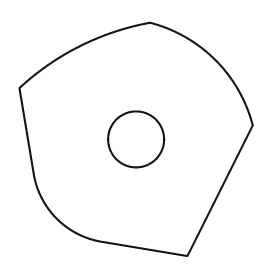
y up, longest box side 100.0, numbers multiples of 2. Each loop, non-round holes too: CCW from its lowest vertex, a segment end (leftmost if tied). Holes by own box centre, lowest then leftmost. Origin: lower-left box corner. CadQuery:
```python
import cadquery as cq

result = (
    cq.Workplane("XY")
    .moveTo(72.0, 0.0)
    .lineTo(100.0, 56.0)
    .threePointArc((84.0, 84.0), (56.0, 100.0))
    .threePointArc((26.0, 90.0), (0.0, 72.0))
    .lineTo(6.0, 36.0)
    .threePointArc((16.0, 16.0), (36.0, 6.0))
    .close()
    .moveTo(50.0, 50.0)
    .circle(12.0)
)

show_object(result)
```